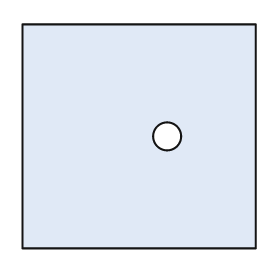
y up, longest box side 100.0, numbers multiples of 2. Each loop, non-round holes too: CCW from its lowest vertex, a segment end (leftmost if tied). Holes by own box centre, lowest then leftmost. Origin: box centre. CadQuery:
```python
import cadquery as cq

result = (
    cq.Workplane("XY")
    .moveTo(-50.0, -48.0)
    .lineTo(50.0, -48.0)
    .lineTo(50.0, 48.0)
    .lineTo(-50.0, 48.0)
    .close()
    .moveTo(12.0, 0.0)
    .circle(6.0)
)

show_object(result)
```